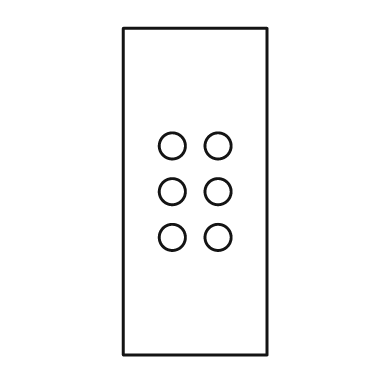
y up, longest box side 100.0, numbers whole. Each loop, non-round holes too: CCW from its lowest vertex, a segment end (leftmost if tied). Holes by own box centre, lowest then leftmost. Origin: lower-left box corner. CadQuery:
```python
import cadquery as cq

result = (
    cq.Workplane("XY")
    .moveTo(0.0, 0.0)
    .lineTo(44.0, 0.0)
    .lineTo(44.0, 100.0)
    .lineTo(0.0, 100.0)
    .close()
    .moveTo(15.0, 36.0)
    .circle(4.0)
    .moveTo(29.0, 36.0)
    .circle(4.0)
    .moveTo(15.0, 50.0)
    .circle(4.0)
    .moveTo(29.0, 50.0)
    .circle(4.0)
    .moveTo(15.0, 64.0)
    .circle(4.0)
    .moveTo(29.0, 64.0)
    .circle(4.0)
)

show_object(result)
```